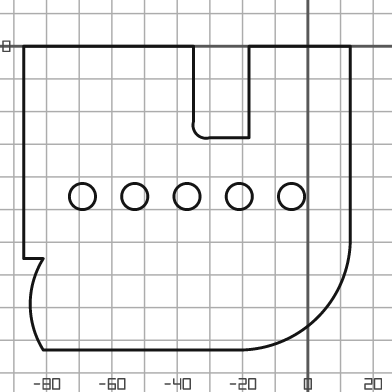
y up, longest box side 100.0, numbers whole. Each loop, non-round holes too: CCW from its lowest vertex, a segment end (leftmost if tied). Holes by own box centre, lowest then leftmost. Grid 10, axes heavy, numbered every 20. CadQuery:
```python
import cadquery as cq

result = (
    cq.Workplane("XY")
    .moveTo(-81.0, -93.0)
    .lineTo(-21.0, -93.0)
    .threePointArc((3.0, -83.0), (13.0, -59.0))
    .lineTo(13.0, 0.0)
    .lineTo(-18.0, 0.0)
    .lineTo(-18.0, -28.0)
    .lineTo(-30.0, -28.0)
    .threePointArc((-34.0, -27.0), (-35.0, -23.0))
    .lineTo(-35.0, 0.0)
    .lineTo(-87.0, 0.0)
    .lineTo(-87.0, -65.0)
    .lineTo(-81.0, -65.0)
    .threePointArc((-85.0, -79.0), (-81.0, -93.0))
    .close()
    .moveTo(-69.0, -46.0)
    .circle(4.0)
    .moveTo(-53.0, -46.0)
    .circle(4.0)
    .moveTo(-37.0, -46.0)
    .circle(4.0)
    .moveTo(-21.0, -46.0)
    .circle(4.0)
    .moveTo(-5.0, -46.0)
    .circle(4.0)
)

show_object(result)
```